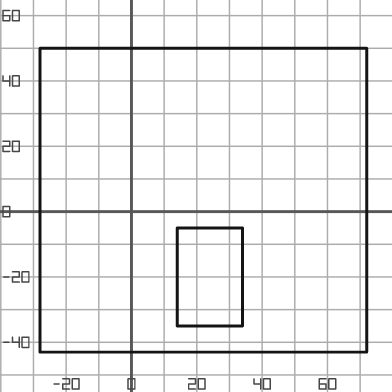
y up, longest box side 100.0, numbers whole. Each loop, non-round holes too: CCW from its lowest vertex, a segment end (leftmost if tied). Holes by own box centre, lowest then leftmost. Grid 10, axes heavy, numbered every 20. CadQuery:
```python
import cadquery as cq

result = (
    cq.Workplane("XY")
    .moveTo(-28.0, -43.0)
    .lineTo(72.0, -43.0)
    .lineTo(72.0, 50.0)
    .lineTo(-28.0, 50.0)
    .close()
    .moveTo(14.0, -35.0)
    .lineTo(34.0, -35.0)
    .lineTo(34.0, -5.0)
    .lineTo(14.0, -5.0)
    .close()
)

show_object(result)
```